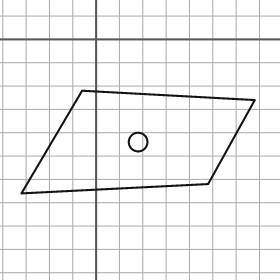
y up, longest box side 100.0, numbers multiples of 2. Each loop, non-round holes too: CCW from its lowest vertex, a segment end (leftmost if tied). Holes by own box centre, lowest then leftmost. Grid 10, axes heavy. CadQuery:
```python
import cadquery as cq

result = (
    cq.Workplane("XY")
    .moveTo(-32.0, -66.0)
    .lineTo(48.0, -62.0)
    .lineTo(68.0, -26.0)
    .lineTo(-6.0, -22.0)
    .close()
    .moveTo(18.0, -44.0)
    .circle(4.0)
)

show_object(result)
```